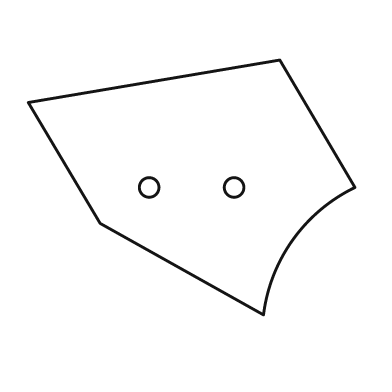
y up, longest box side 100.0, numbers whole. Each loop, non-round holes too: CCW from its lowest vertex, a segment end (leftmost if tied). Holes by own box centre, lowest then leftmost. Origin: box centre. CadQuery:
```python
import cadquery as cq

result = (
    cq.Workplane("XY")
    .moveTo(22.0, -39.0)
    .threePointArc((31.0, -16.0), (50.0, 0.0))
    .lineTo(27.0, 39.0)
    .lineTo(-50.0, 26.0)
    .lineTo(-28.0, -11.0)
    .close()
    .moveTo(-13.0, 0.0)
    .circle(3.0)
    .moveTo(13.0, 0.0)
    .circle(3.0)
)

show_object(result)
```